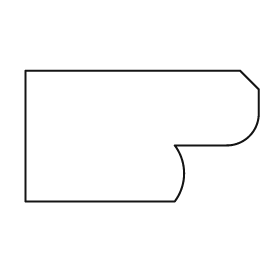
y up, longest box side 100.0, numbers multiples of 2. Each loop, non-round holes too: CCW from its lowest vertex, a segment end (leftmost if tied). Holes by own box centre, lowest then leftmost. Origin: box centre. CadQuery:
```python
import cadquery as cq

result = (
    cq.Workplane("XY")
    .moveTo(-50.0, -28.0)
    .lineTo(14.0, -28.0)
    .threePointArc((18.0, -16.0), (14.0, -4.0))
    .lineTo(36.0, -4.0)
    .threePointArc((46.0, 0.0), (50.0, 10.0))
    .lineTo(50.0, 20.0)
    .lineTo(42.0, 28.0)
    .lineTo(-50.0, 28.0)
    .close()
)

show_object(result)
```